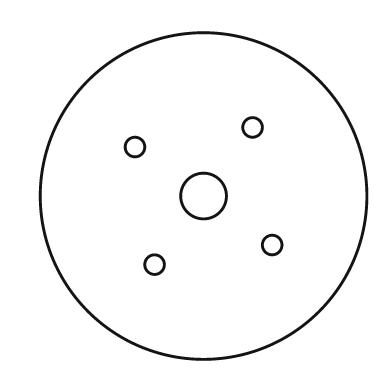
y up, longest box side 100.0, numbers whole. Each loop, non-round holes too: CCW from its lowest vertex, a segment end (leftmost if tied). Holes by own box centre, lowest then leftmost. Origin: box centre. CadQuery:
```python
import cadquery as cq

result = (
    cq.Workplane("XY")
    .moveTo(0.0, 0.0)
    .circle(50.0)
    .moveTo(-15.0, -21.0)
    .circle(3.0)
    .moveTo(21.0, -15.0)
    .circle(3.0)
    .moveTo(0.0, 0.0)
    .circle(7.0)
    .moveTo(-21.0, 15.0)
    .circle(3.0)
    .moveTo(15.0, 21.0)
    .circle(3.0)
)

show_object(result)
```